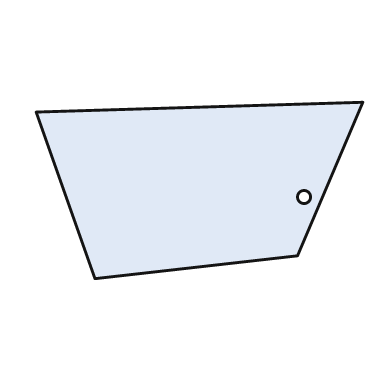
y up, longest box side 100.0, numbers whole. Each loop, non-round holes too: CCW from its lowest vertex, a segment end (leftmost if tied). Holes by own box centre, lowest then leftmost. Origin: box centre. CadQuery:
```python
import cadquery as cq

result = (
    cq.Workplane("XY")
    .moveTo(-32.0, -27.0)
    .lineTo(30.0, -20.0)
    .lineTo(50.0, 27.0)
    .lineTo(-50.0, 24.0)
    .close()
    .moveTo(32.0, -2.0)
    .circle(2.0)
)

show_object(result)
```